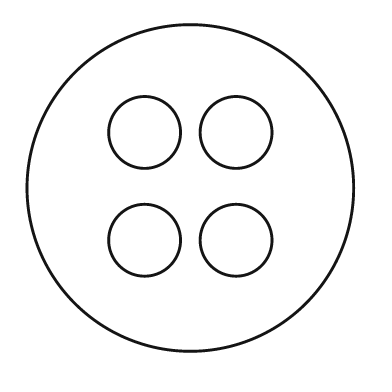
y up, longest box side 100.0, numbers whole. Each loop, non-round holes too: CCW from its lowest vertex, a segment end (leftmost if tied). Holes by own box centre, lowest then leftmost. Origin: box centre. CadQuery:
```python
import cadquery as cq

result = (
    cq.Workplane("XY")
    .moveTo(0.0, 0.0)
    .circle(50.0)
    .moveTo(-14.0, -16.0)
    .circle(11.0)
    .moveTo(14.0, -16.0)
    .circle(11.0)
    .moveTo(-14.0, 17.0)
    .circle(11.0)
    .moveTo(14.0, 17.0)
    .circle(11.0)
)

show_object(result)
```